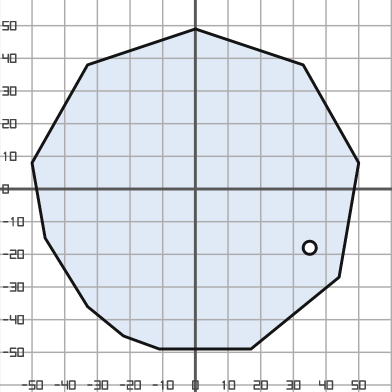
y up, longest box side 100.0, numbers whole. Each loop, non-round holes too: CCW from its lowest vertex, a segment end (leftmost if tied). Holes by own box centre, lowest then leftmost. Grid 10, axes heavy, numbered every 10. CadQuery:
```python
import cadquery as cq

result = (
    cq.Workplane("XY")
    .moveTo(-11.0, -49.0)
    .lineTo(17.0, -49.0)
    .lineTo(44.0, -27.0)
    .lineTo(50.0, 8.0)
    .lineTo(33.0, 38.0)
    .lineTo(0.0, 49.0)
    .lineTo(-33.0, 38.0)
    .lineTo(-50.0, 8.0)
    .lineTo(-46.0, -15.0)
    .lineTo(-33.0, -36.0)
    .lineTo(-22.0, -45.0)
    .close()
    .moveTo(35.0, -18.0)
    .circle(2.0)
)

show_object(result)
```